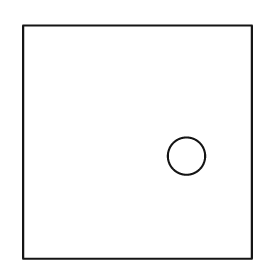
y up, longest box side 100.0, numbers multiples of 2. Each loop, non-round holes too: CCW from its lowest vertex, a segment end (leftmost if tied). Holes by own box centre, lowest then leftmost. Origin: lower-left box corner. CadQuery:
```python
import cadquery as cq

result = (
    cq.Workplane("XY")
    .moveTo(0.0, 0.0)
    .lineTo(98.0, 0.0)
    .lineTo(98.0, 100.0)
    .lineTo(0.0, 100.0)
    .close()
    .moveTo(70.0, 44.0)
    .circle(8.0)
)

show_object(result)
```